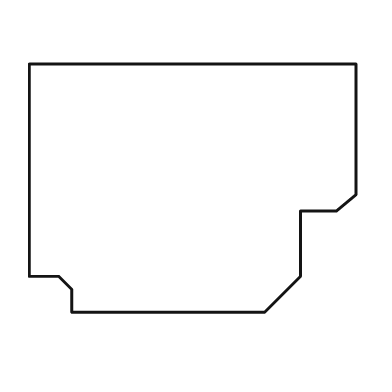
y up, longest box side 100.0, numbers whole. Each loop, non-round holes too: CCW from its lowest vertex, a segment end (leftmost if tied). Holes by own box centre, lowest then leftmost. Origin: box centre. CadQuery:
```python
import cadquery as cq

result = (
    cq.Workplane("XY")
    .moveTo(-37.0, -38.0)
    .lineTo(22.0, -38.0)
    .lineTo(33.0, -27.0)
    .lineTo(33.0, -7.0)
    .lineTo(44.0, -7.0)
    .lineTo(50.0, -2.0)
    .lineTo(50.0, 38.0)
    .lineTo(-50.0, 38.0)
    .lineTo(-50.0, -27.0)
    .lineTo(-41.0, -27.0)
    .lineTo(-37.0, -31.0)
    .close()
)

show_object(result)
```